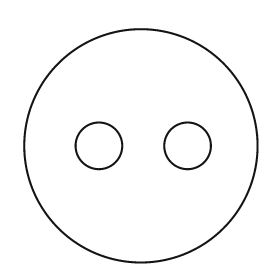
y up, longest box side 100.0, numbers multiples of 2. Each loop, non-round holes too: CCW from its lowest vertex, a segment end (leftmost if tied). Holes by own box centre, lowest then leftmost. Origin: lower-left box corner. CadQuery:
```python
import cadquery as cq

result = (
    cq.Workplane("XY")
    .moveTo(50.0, 50.0)
    .circle(50.0)
    .moveTo(32.0, 50.0)
    .circle(10.0)
    .moveTo(70.0, 50.0)
    .circle(10.0)
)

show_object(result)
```